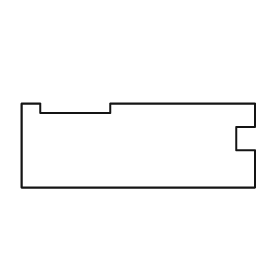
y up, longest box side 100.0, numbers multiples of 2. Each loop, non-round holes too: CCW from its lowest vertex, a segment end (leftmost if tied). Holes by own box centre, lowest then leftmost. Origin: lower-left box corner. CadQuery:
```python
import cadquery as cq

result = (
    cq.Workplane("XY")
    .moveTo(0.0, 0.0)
    .lineTo(100.0, 0.0)
    .lineTo(100.0, 16.0)
    .lineTo(92.0, 16.0)
    .lineTo(92.0, 26.0)
    .lineTo(100.0, 26.0)
    .lineTo(100.0, 36.0)
    .lineTo(38.0, 36.0)
    .lineTo(38.0, 32.0)
    .lineTo(8.0, 32.0)
    .lineTo(8.0, 36.0)
    .lineTo(0.0, 36.0)
    .close()
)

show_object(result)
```